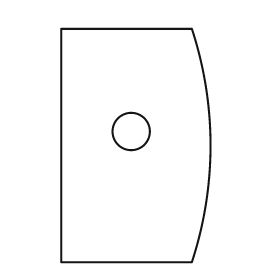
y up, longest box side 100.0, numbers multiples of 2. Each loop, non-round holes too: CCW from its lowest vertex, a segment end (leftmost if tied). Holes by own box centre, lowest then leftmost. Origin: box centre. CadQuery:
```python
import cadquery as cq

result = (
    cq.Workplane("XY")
    .moveTo(-32.0, -50.0)
    .lineTo(24.0, -50.0)
    .threePointArc((32.0, 0.0), (24.0, 50.0))
    .lineTo(-32.0, 50.0)
    .close()
    .moveTo(-2.0, 6.0)
    .circle(8.0)
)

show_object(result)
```